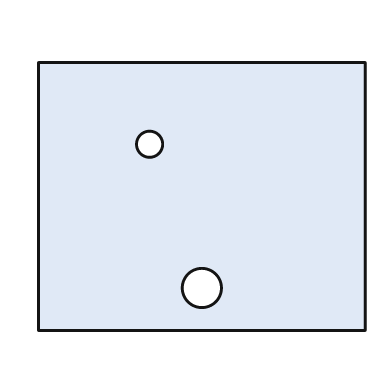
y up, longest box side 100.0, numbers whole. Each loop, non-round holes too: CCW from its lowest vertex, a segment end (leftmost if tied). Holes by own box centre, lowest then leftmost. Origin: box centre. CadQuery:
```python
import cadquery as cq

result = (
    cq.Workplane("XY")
    .moveTo(-50.0, -41.0)
    .lineTo(50.0, -41.0)
    .lineTo(50.0, 41.0)
    .lineTo(-50.0, 41.0)
    .close()
    .moveTo(0.0, -28.0)
    .circle(6.0)
    .moveTo(-16.0, 16.0)
    .circle(4.0)
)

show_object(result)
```